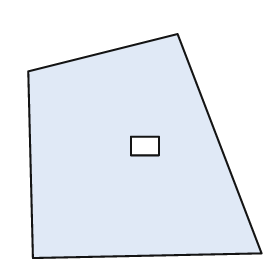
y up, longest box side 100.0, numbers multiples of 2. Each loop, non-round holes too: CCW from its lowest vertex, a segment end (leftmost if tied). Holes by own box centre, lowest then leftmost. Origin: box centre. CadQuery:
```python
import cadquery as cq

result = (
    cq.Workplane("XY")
    .moveTo(-48.0, -48.0)
    .lineTo(50.0, -46.0)
    .lineTo(14.0, 48.0)
    .lineTo(-50.0, 32.0)
    .close()
    .moveTo(-6.0, -4.0)
    .lineTo(6.0, -4.0)
    .lineTo(6.0, 4.0)
    .lineTo(-6.0, 4.0)
    .close()
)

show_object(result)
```